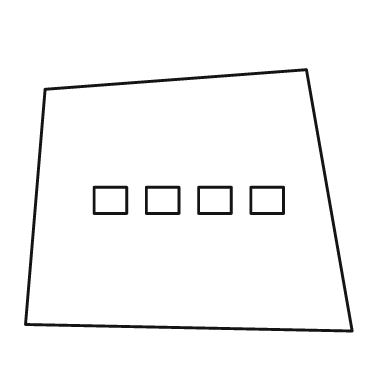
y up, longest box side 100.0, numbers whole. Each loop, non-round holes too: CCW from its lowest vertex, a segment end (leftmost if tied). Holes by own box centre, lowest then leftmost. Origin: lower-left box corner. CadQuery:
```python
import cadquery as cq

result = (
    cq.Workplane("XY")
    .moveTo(100.0, 0.0)
    .lineTo(86.0, 80.0)
    .lineTo(6.0, 74.0)
    .lineTo(0.0, 2.0)
    .close()
    .moveTo(21.0, 36.0)
    .lineTo(31.0, 36.0)
    .lineTo(31.0, 44.0)
    .lineTo(21.0, 44.0)
    .close()
    .moveTo(37.0, 36.0)
    .lineTo(47.0, 36.0)
    .lineTo(47.0, 44.0)
    .lineTo(37.0, 44.0)
    .close()
    .moveTo(53.0, 36.0)
    .lineTo(63.0, 36.0)
    .lineTo(63.0, 44.0)
    .lineTo(53.0, 44.0)
    .close()
    .moveTo(69.0, 36.0)
    .lineTo(79.0, 36.0)
    .lineTo(79.0, 44.0)
    .lineTo(69.0, 44.0)
    .close()
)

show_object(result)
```